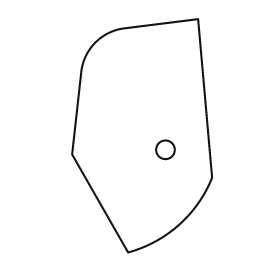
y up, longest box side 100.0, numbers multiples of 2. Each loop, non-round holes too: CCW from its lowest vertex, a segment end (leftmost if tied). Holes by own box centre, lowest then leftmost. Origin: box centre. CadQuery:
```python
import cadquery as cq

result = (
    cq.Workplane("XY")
    .moveTo(-6.0, -50.0)
    .threePointArc((16.0, -38.0), (30.0, -18.0))
    .lineTo(24.0, 50.0)
    .lineTo(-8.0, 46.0)
    .threePointArc((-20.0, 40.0), (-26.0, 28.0))
    .lineTo(-30.0, -8.0)
    .close()
    .moveTo(10.0, -6.0)
    .circle(4.0)
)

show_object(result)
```